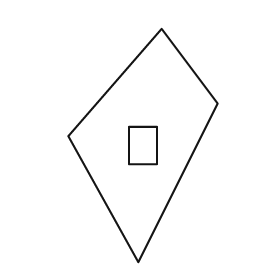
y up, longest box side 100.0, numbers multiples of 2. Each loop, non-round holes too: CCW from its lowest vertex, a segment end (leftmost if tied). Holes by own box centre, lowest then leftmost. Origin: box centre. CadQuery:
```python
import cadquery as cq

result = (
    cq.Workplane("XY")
    .moveTo(-2.0, -50.0)
    .lineTo(32.0, 18.0)
    .lineTo(8.0, 50.0)
    .lineTo(-32.0, 4.0)
    .close()
    .moveTo(-6.0, -8.0)
    .lineTo(6.0, -8.0)
    .lineTo(6.0, 8.0)
    .lineTo(-6.0, 8.0)
    .close()
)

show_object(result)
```